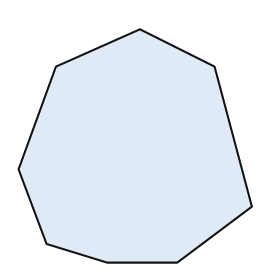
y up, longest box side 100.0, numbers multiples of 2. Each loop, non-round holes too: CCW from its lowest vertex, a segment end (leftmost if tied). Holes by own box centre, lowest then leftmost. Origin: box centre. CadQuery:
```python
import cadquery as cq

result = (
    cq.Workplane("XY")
    .moveTo(-12.0, -50.0)
    .lineTo(18.0, -50.0)
    .lineTo(50.0, -26.0)
    .lineTo(34.0, 34.0)
    .lineTo(2.0, 50.0)
    .lineTo(-34.0, 34.0)
    .lineTo(-50.0, -10.0)
    .lineTo(-38.0, -42.0)
    .close()
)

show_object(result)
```